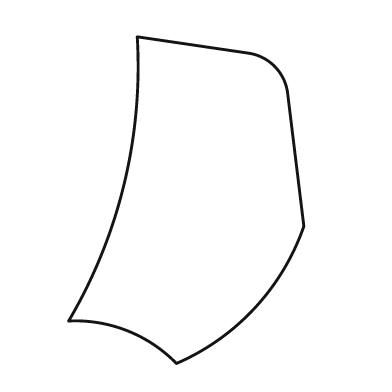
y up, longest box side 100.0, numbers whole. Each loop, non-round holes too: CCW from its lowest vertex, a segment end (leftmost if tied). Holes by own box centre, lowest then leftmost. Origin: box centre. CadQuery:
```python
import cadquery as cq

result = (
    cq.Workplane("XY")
    .moveTo(-3.0, -50.0)
    .threePointArc((21.0, -33.0), (36.0, -8.0))
    .lineTo(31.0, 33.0)
    .threePointArc((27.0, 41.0), (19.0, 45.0))
    .lineTo(-15.0, 50.0)
    .threePointArc((-19.0, 5.0), (-36.0, -37.0))
    .threePointArc((-18.0, -40.0), (-3.0, -50.0))
    .close()
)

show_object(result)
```